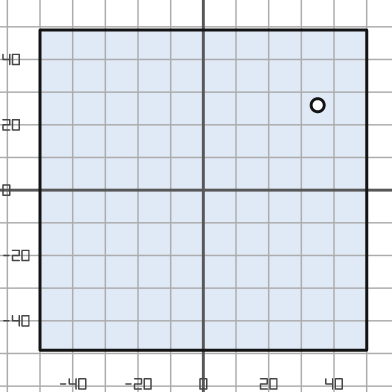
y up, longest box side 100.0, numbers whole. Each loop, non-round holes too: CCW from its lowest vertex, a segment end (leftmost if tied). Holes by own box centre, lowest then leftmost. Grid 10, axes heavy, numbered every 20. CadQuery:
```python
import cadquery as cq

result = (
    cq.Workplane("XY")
    .moveTo(-50.0, -49.0)
    .lineTo(50.0, -49.0)
    .lineTo(50.0, 49.0)
    .lineTo(-50.0, 49.0)
    .close()
    .moveTo(35.0, 26.0)
    .circle(2.0)
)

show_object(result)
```